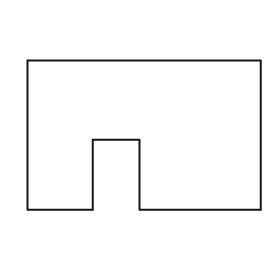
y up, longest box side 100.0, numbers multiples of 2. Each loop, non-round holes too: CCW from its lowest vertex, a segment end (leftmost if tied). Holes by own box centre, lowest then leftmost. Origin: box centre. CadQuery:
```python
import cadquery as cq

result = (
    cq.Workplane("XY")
    .moveTo(-50.0, -32.0)
    .lineTo(-22.0, -32.0)
    .lineTo(-22.0, -2.0)
    .lineTo(-2.0, -2.0)
    .lineTo(-2.0, -32.0)
    .lineTo(50.0, -32.0)
    .lineTo(50.0, 32.0)
    .lineTo(-50.0, 32.0)
    .close()
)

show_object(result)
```